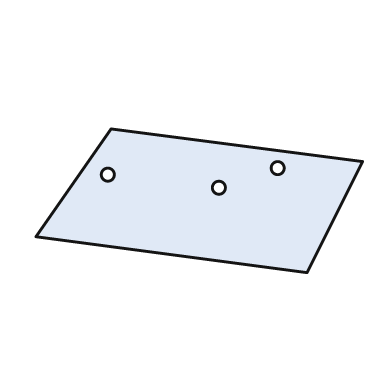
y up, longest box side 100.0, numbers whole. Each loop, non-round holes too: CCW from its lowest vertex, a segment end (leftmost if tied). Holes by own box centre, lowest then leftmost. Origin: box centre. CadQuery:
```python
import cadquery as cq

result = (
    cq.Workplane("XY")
    .moveTo(33.0, -22.0)
    .lineTo(50.0, 12.0)
    .lineTo(-27.0, 22.0)
    .lineTo(-50.0, -11.0)
    .close()
    .moveTo(6.0, 4.0)
    .circle(2.0)
    .moveTo(-28.0, 8.0)
    .circle(2.0)
    .moveTo(24.0, 10.0)
    .circle(2.0)
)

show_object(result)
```